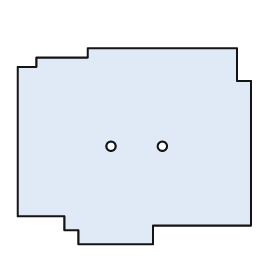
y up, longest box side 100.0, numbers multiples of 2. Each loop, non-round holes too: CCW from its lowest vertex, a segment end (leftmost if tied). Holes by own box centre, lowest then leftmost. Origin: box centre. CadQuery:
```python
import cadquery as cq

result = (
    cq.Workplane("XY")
    .moveTo(-24.0, -42.0)
    .lineTo(8.0, -42.0)
    .lineTo(8.0, -34.0)
    .lineTo(50.0, -34.0)
    .lineTo(50.0, 28.0)
    .lineTo(44.0, 28.0)
    .lineTo(44.0, 42.0)
    .lineTo(-20.0, 42.0)
    .lineTo(-20.0, 38.0)
    .lineTo(-42.0, 38.0)
    .lineTo(-42.0, 34.0)
    .lineTo(-50.0, 34.0)
    .lineTo(-50.0, -30.0)
    .lineTo(-30.0, -30.0)
    .lineTo(-30.0, -36.0)
    .lineTo(-24.0, -36.0)
    .close()
    .moveTo(-10.0, 0.0)
    .circle(2.0)
    .moveTo(12.0, 0.0)
    .circle(2.0)
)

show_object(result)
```